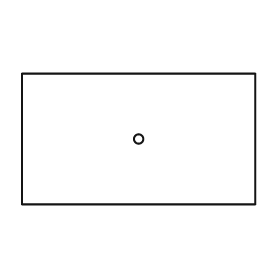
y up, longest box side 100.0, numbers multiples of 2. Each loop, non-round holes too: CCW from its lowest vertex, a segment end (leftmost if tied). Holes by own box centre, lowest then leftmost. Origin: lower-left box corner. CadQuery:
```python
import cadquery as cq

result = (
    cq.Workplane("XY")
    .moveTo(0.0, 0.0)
    .lineTo(100.0, 0.0)
    .lineTo(100.0, 56.0)
    .lineTo(0.0, 56.0)
    .close()
    .moveTo(50.0, 28.0)
    .circle(2.0)
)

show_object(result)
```